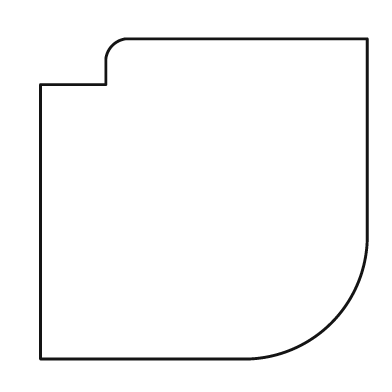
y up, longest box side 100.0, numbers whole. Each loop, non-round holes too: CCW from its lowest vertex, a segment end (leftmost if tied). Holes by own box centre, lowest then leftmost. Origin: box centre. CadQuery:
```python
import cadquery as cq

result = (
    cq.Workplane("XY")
    .moveTo(-50.0, -49.0)
    .lineTo(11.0, -49.0)
    .threePointArc((39.0, -38.0), (50.0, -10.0))
    .lineTo(50.0, 49.0)
    .lineTo(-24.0, 49.0)
    .threePointArc((-28.0, 47.0), (-30.0, 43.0))
    .lineTo(-30.0, 35.0)
    .lineTo(-50.0, 35.0)
    .close()
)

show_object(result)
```